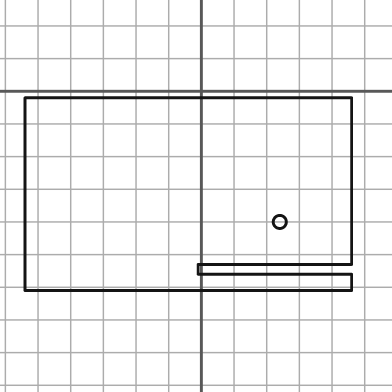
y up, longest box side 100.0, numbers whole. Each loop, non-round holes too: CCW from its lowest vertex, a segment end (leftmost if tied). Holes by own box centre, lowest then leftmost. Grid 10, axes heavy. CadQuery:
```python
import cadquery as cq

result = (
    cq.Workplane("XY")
    .moveTo(-54.0, -61.0)
    .lineTo(46.0, -61.0)
    .lineTo(46.0, -56.0)
    .lineTo(-1.0, -56.0)
    .lineTo(-1.0, -53.0)
    .lineTo(46.0, -53.0)
    .lineTo(46.0, -2.0)
    .lineTo(-54.0, -2.0)
    .close()
    .moveTo(24.0, -40.0)
    .circle(2.0)
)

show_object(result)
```